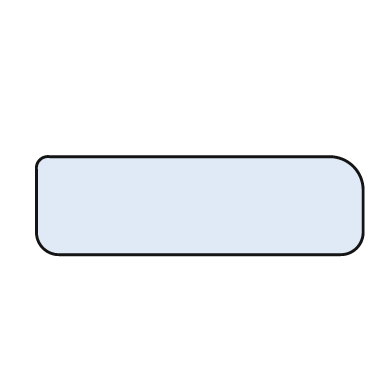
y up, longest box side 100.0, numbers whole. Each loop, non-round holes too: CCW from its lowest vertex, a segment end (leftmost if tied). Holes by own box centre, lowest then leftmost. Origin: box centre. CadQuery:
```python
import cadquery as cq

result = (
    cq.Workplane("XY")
    .moveTo(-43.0, -15.0)
    .lineTo(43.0, -15.0)
    .threePointArc((48.0, -13.0), (50.0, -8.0))
    .lineTo(50.0, 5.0)
    .threePointArc((47.0, 12.0), (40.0, 15.0))
    .lineTo(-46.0, 15.0)
    .threePointArc((-49.0, 14.0), (-50.0, 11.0))
    .lineTo(-50.0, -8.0)
    .threePointArc((-48.0, -13.0), (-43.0, -15.0))
    .close()
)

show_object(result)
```